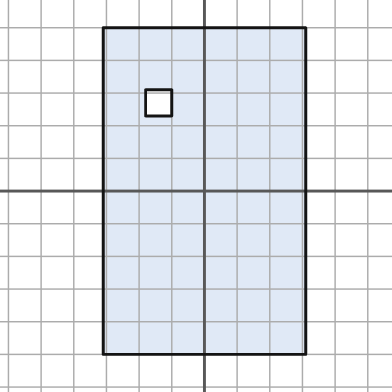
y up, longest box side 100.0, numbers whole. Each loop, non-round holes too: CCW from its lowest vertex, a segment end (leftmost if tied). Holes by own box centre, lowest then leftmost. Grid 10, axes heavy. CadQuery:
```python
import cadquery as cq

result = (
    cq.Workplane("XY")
    .moveTo(-31.0, -50.0)
    .lineTo(31.0, -50.0)
    .lineTo(31.0, 50.0)
    .lineTo(-31.0, 50.0)
    .close()
    .moveTo(-18.0, 23.0)
    .lineTo(-10.0, 23.0)
    .lineTo(-10.0, 31.0)
    .lineTo(-18.0, 31.0)
    .close()
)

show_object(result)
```